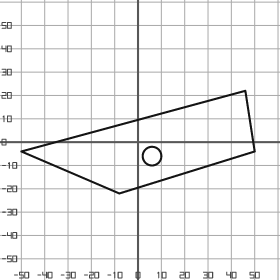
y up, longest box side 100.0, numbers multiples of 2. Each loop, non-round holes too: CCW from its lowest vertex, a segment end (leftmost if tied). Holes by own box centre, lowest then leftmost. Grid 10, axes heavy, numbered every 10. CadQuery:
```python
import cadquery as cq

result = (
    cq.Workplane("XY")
    .moveTo(-8.0, -22.0)
    .lineTo(50.0, -4.0)
    .lineTo(46.0, 22.0)
    .lineTo(-50.0, -4.0)
    .close()
    .moveTo(6.0, -6.0)
    .circle(4.0)
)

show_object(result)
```